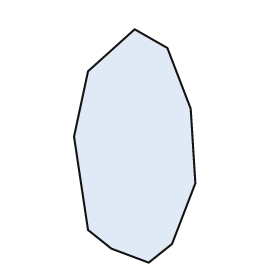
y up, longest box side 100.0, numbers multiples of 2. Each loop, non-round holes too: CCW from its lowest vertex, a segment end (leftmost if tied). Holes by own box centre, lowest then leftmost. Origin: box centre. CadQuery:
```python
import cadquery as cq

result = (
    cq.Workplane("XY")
    .moveTo(6.0, -50.0)
    .lineTo(16.0, -42.0)
    .lineTo(26.0, -16.0)
    .lineTo(24.0, 16.0)
    .lineTo(14.0, 42.0)
    .lineTo(0.0, 50.0)
    .lineTo(-20.0, 32.0)
    .lineTo(-26.0, 4.0)
    .lineTo(-20.0, -36.0)
    .lineTo(-10.0, -44.0)
    .close()
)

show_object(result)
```